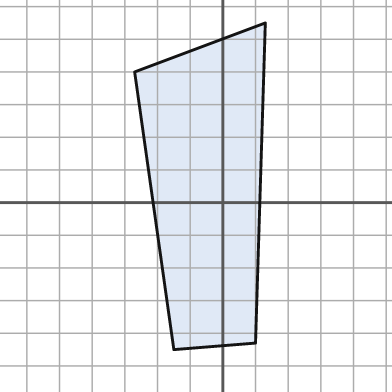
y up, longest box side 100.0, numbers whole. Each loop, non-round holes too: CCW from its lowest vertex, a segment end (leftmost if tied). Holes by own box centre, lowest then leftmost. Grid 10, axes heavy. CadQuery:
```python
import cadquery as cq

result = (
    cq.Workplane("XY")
    .moveTo(-15.0, -45.0)
    .lineTo(10.0, -43.0)
    .lineTo(13.0, 55.0)
    .lineTo(-27.0, 40.0)
    .close()
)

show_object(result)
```